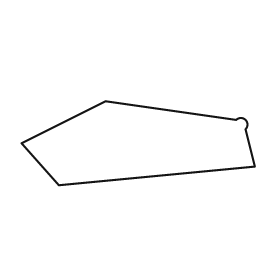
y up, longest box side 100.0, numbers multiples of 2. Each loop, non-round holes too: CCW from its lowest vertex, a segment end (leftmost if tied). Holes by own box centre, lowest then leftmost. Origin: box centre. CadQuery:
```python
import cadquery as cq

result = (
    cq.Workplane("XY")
    .moveTo(-34.0, -18.0)
    .lineTo(50.0, -10.0)
    .lineTo(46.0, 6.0)
    .threePointArc((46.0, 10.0), (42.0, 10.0))
    .lineTo(-14.0, 18.0)
    .lineTo(-50.0, 0.0)
    .close()
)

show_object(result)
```